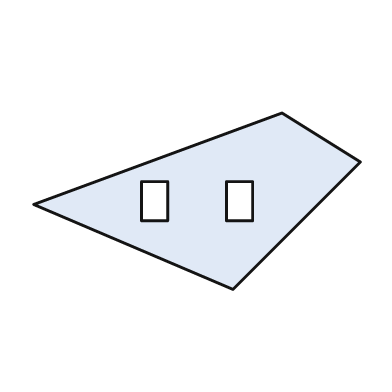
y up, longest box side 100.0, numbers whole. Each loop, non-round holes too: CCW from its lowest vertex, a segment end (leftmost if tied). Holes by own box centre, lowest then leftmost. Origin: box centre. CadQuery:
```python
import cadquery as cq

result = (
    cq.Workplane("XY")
    .moveTo(11.0, -27.0)
    .lineTo(50.0, 12.0)
    .lineTo(26.0, 27.0)
    .lineTo(-50.0, -1.0)
    .close()
    .moveTo(-17.0, -6.0)
    .lineTo(-9.0, -6.0)
    .lineTo(-9.0, 6.0)
    .lineTo(-17.0, 6.0)
    .close()
    .moveTo(9.0, -6.0)
    .lineTo(17.0, -6.0)
    .lineTo(17.0, 6.0)
    .lineTo(9.0, 6.0)
    .close()
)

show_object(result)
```